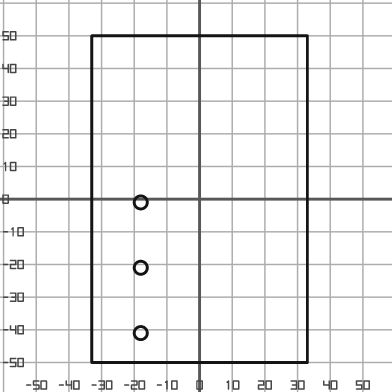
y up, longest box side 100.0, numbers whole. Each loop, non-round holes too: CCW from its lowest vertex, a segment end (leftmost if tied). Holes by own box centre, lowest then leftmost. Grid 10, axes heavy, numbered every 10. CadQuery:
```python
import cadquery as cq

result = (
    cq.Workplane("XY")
    .moveTo(-33.0, -50.0)
    .lineTo(33.0, -50.0)
    .lineTo(33.0, 50.0)
    .lineTo(-33.0, 50.0)
    .close()
    .moveTo(-18.0, -41.0)
    .circle(2.0)
    .moveTo(-18.0, -21.0)
    .circle(2.0)
    .moveTo(-18.0, -1.0)
    .circle(2.0)
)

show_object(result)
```